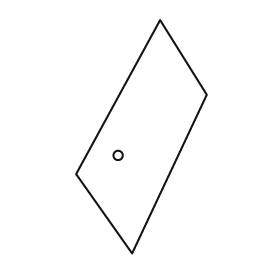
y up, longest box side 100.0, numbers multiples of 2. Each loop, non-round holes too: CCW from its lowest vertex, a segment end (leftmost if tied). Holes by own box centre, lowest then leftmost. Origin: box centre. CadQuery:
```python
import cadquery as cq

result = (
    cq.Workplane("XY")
    .moveTo(-4.0, -50.0)
    .lineTo(28.0, 18.0)
    .lineTo(8.0, 50.0)
    .lineTo(-28.0, -16.0)
    .close()
    .moveTo(-10.0, -8.0)
    .circle(2.0)
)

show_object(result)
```